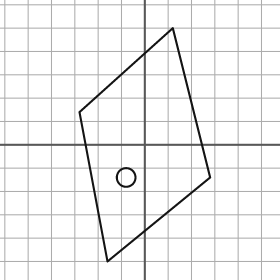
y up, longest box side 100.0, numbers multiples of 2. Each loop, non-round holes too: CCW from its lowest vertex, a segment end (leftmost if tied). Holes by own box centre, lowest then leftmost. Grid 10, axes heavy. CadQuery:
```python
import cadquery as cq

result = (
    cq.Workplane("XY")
    .moveTo(-16.0, -50.0)
    .lineTo(28.0, -14.0)
    .lineTo(12.0, 50.0)
    .lineTo(-28.0, 14.0)
    .close()
    .moveTo(-8.0, -14.0)
    .circle(4.0)
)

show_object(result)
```